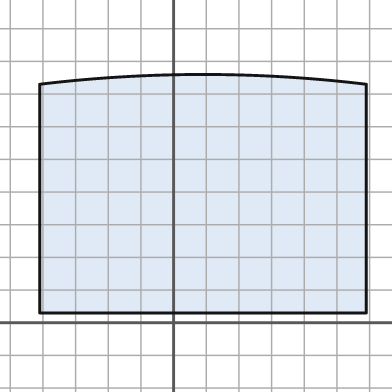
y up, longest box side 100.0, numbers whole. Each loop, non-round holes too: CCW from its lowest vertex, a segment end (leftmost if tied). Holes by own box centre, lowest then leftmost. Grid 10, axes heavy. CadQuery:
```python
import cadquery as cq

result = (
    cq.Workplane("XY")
    .moveTo(-41.0, 3.0)
    .lineTo(59.0, 3.0)
    .lineTo(59.0, 73.0)
    .threePointArc((9.0, 76.0), (-41.0, 73.0))
    .close()
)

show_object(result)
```